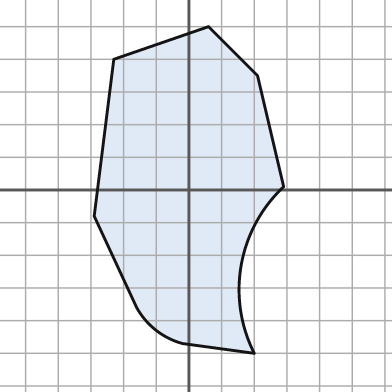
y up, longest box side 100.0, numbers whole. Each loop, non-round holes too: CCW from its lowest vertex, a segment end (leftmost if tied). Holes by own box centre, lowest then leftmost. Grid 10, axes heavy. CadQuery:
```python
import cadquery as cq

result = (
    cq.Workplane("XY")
    .moveTo(20.0, -50.0)
    .threePointArc((16.0, -23.0), (29.0, 1.0))
    .lineTo(21.0, 35.0)
    .lineTo(6.0, 50.0)
    .lineTo(-23.0, 40.0)
    .lineTo(-29.0, -8.0)
    .lineTo(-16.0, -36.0)
    .threePointArc((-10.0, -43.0), (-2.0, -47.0))
    .close()
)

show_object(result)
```